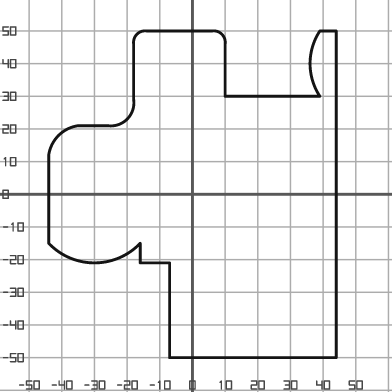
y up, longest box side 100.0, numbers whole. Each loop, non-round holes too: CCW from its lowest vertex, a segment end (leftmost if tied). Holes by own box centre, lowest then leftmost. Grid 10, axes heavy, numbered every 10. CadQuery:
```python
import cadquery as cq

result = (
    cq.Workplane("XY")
    .moveTo(-7.0, -50.0)
    .lineTo(44.0, -50.0)
    .lineTo(44.0, 50.0)
    .lineTo(39.0, 50.0)
    .threePointArc((36.0, 40.0), (39.0, 30.0))
    .lineTo(10.0, 30.0)
    .lineTo(10.0, 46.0)
    .threePointArc((9.0, 49.0), (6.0, 50.0))
    .lineTo(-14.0, 50.0)
    .threePointArc((-17.0, 49.0), (-18.0, 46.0))
    .lineTo(-18.0, 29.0)
    .threePointArc((-20.0, 23.0), (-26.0, 21.0))
    .lineTo(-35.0, 21.0)
    .threePointArc((-41.0, 18.0), (-44.0, 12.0))
    .lineTo(-44.0, -15.0)
    .threePointArc((-30.0, -21.0), (-16.0, -15.0))
    .lineTo(-16.0, -21.0)
    .lineTo(-7.0, -21.0)
    .close()
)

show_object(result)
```